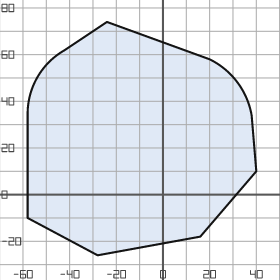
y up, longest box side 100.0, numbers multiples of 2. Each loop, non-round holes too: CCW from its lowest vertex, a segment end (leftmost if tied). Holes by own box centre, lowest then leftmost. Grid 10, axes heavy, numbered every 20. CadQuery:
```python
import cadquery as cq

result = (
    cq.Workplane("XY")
    .moveTo(-28.0, -26.0)
    .lineTo(16.0, -18.0)
    .lineTo(40.0, 10.0)
    .lineTo(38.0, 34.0)
    .threePointArc((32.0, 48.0), (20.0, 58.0))
    .lineTo(-24.0, 74.0)
    .lineTo(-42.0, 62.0)
    .threePointArc((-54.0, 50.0), (-58.0, 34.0))
    .lineTo(-58.0, -10.0)
    .close()
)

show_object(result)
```